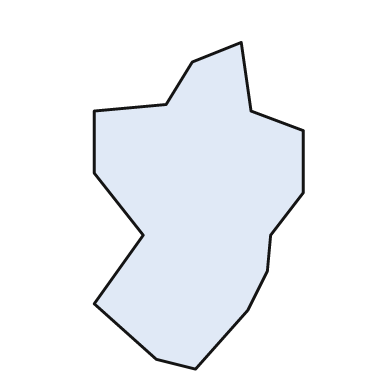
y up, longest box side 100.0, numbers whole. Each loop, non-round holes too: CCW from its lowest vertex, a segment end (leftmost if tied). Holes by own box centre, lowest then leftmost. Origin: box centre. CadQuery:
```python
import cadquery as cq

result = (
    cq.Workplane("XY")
    .moveTo(-1.0, -50.0)
    .lineTo(15.0, -32.0)
    .lineTo(21.0, -20.0)
    .lineTo(22.0, -9.0)
    .lineTo(32.0, 4.0)
    .lineTo(32.0, 23.0)
    .lineTo(16.0, 29.0)
    .lineTo(13.0, 50.0)
    .lineTo(-2.0, 44.0)
    .lineTo(-10.0, 31.0)
    .lineTo(-32.0, 29.0)
    .lineTo(-32.0, 10.0)
    .lineTo(-17.0, -9.0)
    .lineTo(-32.0, -30.0)
    .lineTo(-13.0, -47.0)
    .close()
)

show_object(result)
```